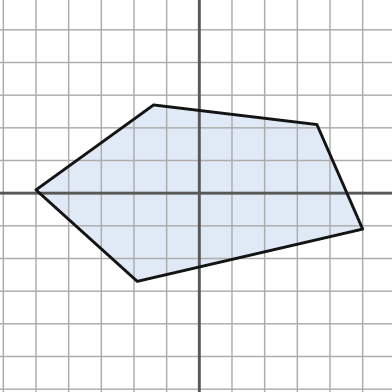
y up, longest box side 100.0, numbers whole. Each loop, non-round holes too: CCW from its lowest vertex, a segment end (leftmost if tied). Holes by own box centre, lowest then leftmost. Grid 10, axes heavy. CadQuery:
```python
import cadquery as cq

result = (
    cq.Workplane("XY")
    .moveTo(-19.0, -27.0)
    .lineTo(50.0, -11.0)
    .lineTo(36.0, 21.0)
    .lineTo(-14.0, 27.0)
    .lineTo(-50.0, 1.0)
    .close()
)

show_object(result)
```